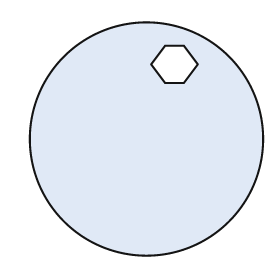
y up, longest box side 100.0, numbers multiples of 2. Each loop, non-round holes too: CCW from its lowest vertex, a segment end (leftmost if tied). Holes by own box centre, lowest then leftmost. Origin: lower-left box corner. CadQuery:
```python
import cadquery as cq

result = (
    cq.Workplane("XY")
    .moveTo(50.0, 50.0)
    .circle(50.0)
    .moveTo(58.0, 74.0)
    .lineTo(66.0, 74.0)
    .lineTo(72.0, 82.0)
    .lineTo(66.0, 90.0)
    .lineTo(58.0, 90.0)
    .lineTo(52.0, 82.0)
    .close()
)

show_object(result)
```